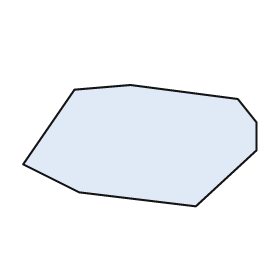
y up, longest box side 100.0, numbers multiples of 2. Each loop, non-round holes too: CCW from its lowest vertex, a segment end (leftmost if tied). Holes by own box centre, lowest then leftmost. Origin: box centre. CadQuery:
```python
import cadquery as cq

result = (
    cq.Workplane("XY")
    .moveTo(24.0, -26.0)
    .lineTo(50.0, -2.0)
    .lineTo(50.0, 10.0)
    .lineTo(42.0, 20.0)
    .lineTo(-4.0, 26.0)
    .lineTo(-28.0, 24.0)
    .lineTo(-50.0, -8.0)
    .lineTo(-26.0, -20.0)
    .close()
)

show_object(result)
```